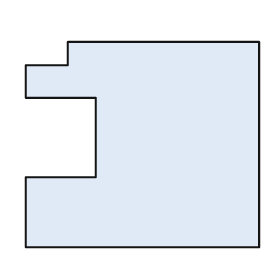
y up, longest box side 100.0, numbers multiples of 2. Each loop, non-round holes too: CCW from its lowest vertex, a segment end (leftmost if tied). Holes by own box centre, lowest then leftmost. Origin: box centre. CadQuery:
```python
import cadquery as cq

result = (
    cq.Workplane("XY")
    .moveTo(-50.0, -44.0)
    .lineTo(50.0, -44.0)
    .lineTo(50.0, 44.0)
    .lineTo(-32.0, 44.0)
    .lineTo(-32.0, 34.0)
    .lineTo(-50.0, 34.0)
    .lineTo(-50.0, 20.0)
    .lineTo(-20.0, 20.0)
    .lineTo(-20.0, -14.0)
    .lineTo(-50.0, -14.0)
    .close()
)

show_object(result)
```